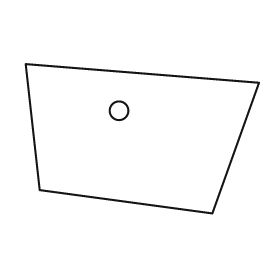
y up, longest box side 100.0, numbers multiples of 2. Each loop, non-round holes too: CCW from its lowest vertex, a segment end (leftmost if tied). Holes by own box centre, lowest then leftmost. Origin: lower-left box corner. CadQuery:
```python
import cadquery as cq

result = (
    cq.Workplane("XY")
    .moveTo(80.0, 0.0)
    .lineTo(100.0, 56.0)
    .lineTo(0.0, 64.0)
    .lineTo(6.0, 10.0)
    .close()
    .moveTo(40.0, 44.0)
    .circle(4.0)
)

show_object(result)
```